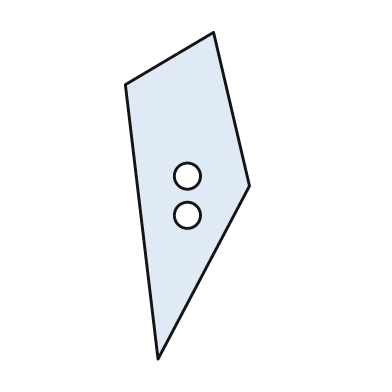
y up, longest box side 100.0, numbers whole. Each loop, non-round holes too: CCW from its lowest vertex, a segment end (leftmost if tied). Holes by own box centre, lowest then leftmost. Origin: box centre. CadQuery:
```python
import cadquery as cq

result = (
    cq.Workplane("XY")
    .moveTo(-9.0, -50.0)
    .lineTo(19.0, 3.0)
    .lineTo(8.0, 50.0)
    .lineTo(-19.0, 34.0)
    .close()
    .moveTo(0.0, -6.0)
    .circle(4.0)
    .moveTo(0.0, 6.0)
    .circle(4.0)
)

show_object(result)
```